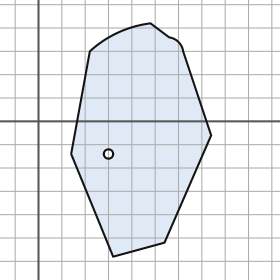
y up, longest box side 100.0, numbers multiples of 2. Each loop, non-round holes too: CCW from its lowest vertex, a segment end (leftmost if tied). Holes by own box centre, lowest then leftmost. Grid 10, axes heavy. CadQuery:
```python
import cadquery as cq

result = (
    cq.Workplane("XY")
    .moveTo(32.0, -58.0)
    .lineTo(54.0, -52.0)
    .lineTo(74.0, -6.0)
    .lineTo(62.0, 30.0)
    .threePointArc((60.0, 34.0), (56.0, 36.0))
    .lineTo(48.0, 42.0)
    .threePointArc((34.0, 38.0), (22.0, 30.0))
    .lineTo(14.0, -14.0)
    .close()
    .moveTo(30.0, -14.0)
    .circle(2.0)
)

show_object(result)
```